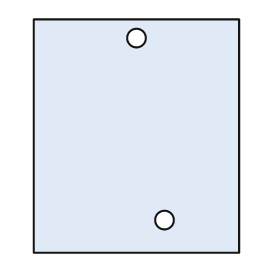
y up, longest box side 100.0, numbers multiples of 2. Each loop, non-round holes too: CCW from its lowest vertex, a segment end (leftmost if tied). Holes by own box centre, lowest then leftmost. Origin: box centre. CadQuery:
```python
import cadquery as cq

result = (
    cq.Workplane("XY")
    .moveTo(-44.0, -50.0)
    .lineTo(44.0, -50.0)
    .lineTo(44.0, 50.0)
    .lineTo(-44.0, 50.0)
    .close()
    .moveTo(12.0, -36.0)
    .circle(4.0)
    .moveTo(0.0, 42.0)
    .circle(4.0)
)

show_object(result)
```